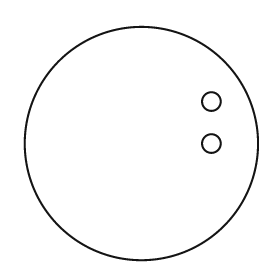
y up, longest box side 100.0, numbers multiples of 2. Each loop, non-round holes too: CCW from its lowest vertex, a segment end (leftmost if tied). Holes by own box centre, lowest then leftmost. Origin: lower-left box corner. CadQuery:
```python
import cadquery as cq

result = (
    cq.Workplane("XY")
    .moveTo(50.0, 50.0)
    .circle(50.0)
    .moveTo(80.0, 50.0)
    .circle(4.0)
    .moveTo(80.0, 68.0)
    .circle(4.0)
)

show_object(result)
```